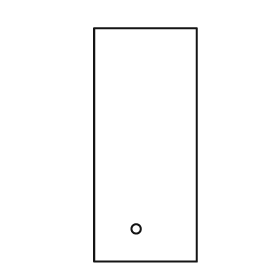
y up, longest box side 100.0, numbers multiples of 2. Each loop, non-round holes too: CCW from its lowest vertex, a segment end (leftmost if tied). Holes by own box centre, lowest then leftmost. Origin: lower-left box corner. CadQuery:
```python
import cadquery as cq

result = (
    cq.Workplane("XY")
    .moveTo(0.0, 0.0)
    .lineTo(44.0, 0.0)
    .lineTo(44.0, 100.0)
    .lineTo(0.0, 100.0)
    .close()
    .moveTo(18.0, 14.0)
    .circle(2.0)
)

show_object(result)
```